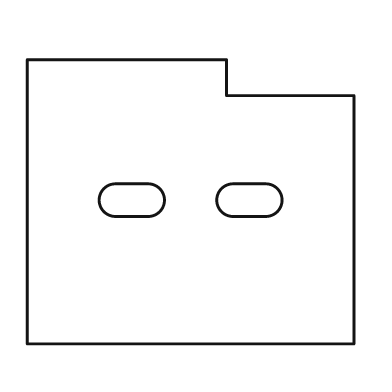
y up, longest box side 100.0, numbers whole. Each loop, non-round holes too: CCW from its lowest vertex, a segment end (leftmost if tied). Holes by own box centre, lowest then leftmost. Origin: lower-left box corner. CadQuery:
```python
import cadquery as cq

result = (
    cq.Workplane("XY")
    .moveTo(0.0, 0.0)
    .lineTo(100.0, 0.0)
    .lineTo(100.0, 76.0)
    .lineTo(61.0, 76.0)
    .lineTo(61.0, 87.0)
    .lineTo(0.0, 87.0)
    .close()
    .moveTo(27.0, 39.0)
    .lineTo(37.0, 39.0)
    .threePointArc((42.0, 44.0), (37.0, 49.0))
    .lineTo(27.0, 49.0)
    .threePointArc((22.0, 44.0), (27.0, 39.0))
    .close()
    .moveTo(63.0, 39.0)
    .lineTo(73.0, 39.0)
    .threePointArc((78.0, 44.0), (73.0, 49.0))
    .lineTo(63.0, 49.0)
    .threePointArc((58.0, 44.0), (63.0, 39.0))
    .close()
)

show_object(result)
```